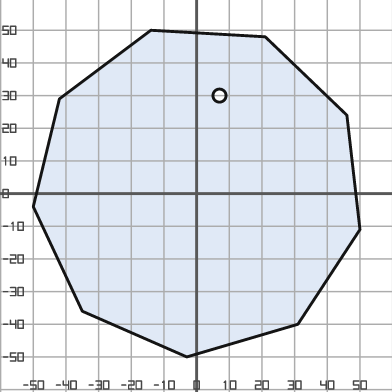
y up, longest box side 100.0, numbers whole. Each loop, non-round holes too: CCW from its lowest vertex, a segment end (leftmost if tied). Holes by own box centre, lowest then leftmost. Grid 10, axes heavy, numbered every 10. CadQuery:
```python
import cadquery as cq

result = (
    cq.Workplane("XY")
    .moveTo(-3.0, -50.0)
    .lineTo(31.0, -40.0)
    .lineTo(50.0, -11.0)
    .lineTo(46.0, 24.0)
    .lineTo(21.0, 48.0)
    .lineTo(-14.0, 50.0)
    .lineTo(-42.0, 29.0)
    .lineTo(-50.0, -4.0)
    .lineTo(-35.0, -36.0)
    .close()
    .moveTo(7.0, 30.0)
    .circle(2.0)
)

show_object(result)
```